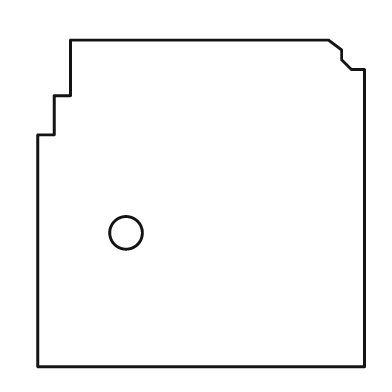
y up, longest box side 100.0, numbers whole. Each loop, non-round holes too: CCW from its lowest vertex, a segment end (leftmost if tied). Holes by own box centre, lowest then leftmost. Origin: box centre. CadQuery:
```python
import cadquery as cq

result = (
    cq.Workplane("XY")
    .moveTo(-50.0, -50.0)
    .lineTo(50.0, -50.0)
    .lineTo(50.0, 41.0)
    .lineTo(46.0, 41.0)
    .lineTo(43.0, 44.0)
    .lineTo(43.0, 47.0)
    .lineTo(39.0, 50.0)
    .lineTo(-40.0, 50.0)
    .lineTo(-40.0, 33.0)
    .lineTo(-45.0, 33.0)
    .lineTo(-45.0, 21.0)
    .lineTo(-50.0, 21.0)
    .close()
    .moveTo(-23.0, -9.0)
    .circle(5.0)
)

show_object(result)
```